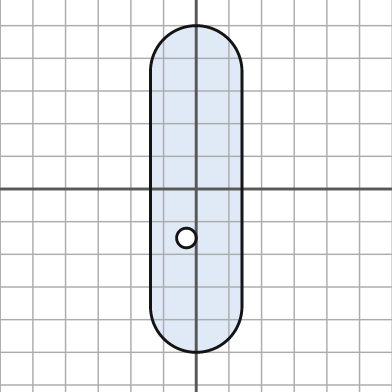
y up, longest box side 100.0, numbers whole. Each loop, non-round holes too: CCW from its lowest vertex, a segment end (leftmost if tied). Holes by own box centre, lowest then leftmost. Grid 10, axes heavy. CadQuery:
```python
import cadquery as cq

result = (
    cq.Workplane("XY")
    .moveTo(-14.0, -36.0)
    .threePointArc((0.0, -50.0), (14.0, -36.0))
    .lineTo(14.0, 36.0)
    .threePointArc((0.0, 50.0), (-14.0, 36.0))
    .close()
    .moveTo(-3.0, -15.0)
    .circle(3.0)
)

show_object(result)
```